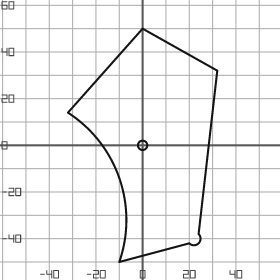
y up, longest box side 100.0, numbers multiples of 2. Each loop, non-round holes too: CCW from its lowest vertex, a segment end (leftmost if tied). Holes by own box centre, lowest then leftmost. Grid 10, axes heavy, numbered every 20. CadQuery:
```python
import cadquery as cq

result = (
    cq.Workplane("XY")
    .moveTo(-10.0, -50.0)
    .lineTo(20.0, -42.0)
    .threePointArc((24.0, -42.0), (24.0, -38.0))
    .lineTo(32.0, 32.0)
    .lineTo(0.0, 50.0)
    .lineTo(-32.0, 14.0)
    .threePointArc((-10.0, -14.0), (-10.0, -50.0))
    .close()
    .moveTo(0.0, 0.0)
    .circle(2.0)
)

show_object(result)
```